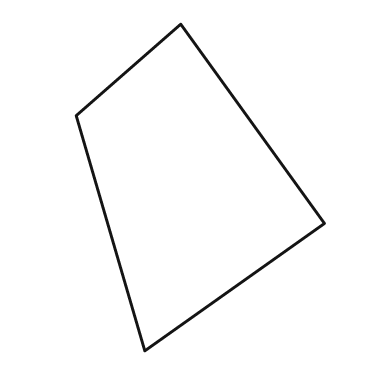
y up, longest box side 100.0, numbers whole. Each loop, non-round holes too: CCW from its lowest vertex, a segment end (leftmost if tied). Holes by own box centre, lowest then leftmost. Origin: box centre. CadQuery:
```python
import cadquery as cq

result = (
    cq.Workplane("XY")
    .moveTo(-17.0, -50.0)
    .lineTo(38.0, -11.0)
    .lineTo(-6.0, 50.0)
    .lineTo(-38.0, 22.0)
    .close()
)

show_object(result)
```